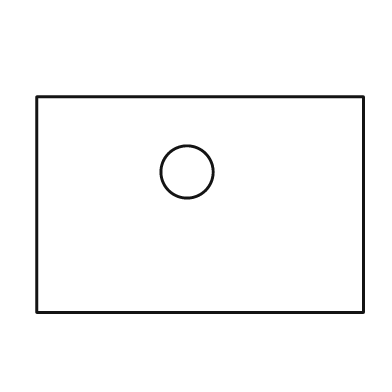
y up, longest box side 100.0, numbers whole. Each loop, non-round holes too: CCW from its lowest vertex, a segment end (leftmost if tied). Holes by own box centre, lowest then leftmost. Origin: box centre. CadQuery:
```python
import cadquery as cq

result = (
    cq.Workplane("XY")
    .moveTo(-50.0, -33.0)
    .lineTo(50.0, -33.0)
    .lineTo(50.0, 33.0)
    .lineTo(-50.0, 33.0)
    .close()
    .moveTo(-4.0, 10.0)
    .circle(8.0)
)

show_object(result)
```